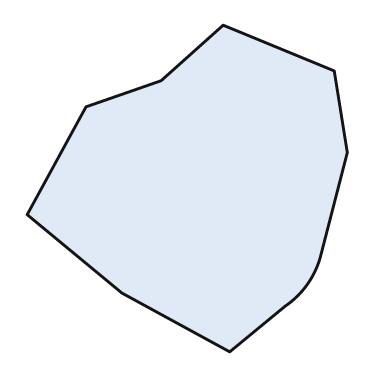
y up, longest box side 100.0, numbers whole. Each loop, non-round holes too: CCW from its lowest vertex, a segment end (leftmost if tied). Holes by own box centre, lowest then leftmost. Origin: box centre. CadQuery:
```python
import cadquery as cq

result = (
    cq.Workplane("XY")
    .moveTo(13.0, -50.0)
    .lineTo(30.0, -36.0)
    .threePointArc((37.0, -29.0), (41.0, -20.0))
    .lineTo(49.0, 11.0)
    .lineTo(45.0, 36.0)
    .lineTo(11.0, 50.0)
    .lineTo(-8.0, 33.0)
    .lineTo(-31.0, 25.0)
    .lineTo(-49.0, -8.0)
    .lineTo(-20.0, -32.0)
    .close()
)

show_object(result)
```